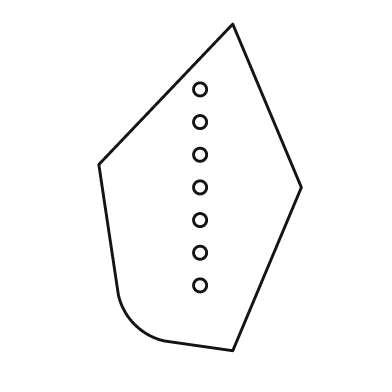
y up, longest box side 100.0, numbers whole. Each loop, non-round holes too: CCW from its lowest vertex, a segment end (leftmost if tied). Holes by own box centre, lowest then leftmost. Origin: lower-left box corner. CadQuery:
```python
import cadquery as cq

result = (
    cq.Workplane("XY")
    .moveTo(41.0, 0.0)
    .lineTo(62.0, 50.0)
    .lineTo(41.0, 100.0)
    .lineTo(0.0, 57.0)
    .lineTo(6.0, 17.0)
    .threePointArc((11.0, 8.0), (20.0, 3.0))
    .close()
    .moveTo(31.0, 20.0)
    .circle(2.0)
    .moveTo(31.0, 30.0)
    .circle(2.0)
    .moveTo(31.0, 40.0)
    .circle(2.0)
    .moveTo(31.0, 50.0)
    .circle(2.0)
    .moveTo(31.0, 60.0)
    .circle(2.0)
    .moveTo(31.0, 70.0)
    .circle(2.0)
    .moveTo(31.0, 80.0)
    .circle(2.0)
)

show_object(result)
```